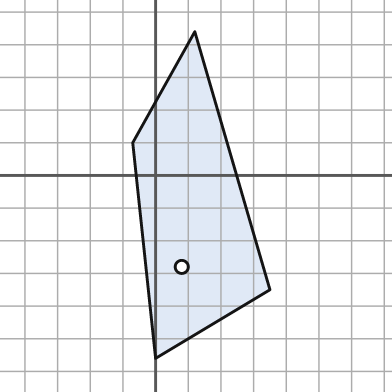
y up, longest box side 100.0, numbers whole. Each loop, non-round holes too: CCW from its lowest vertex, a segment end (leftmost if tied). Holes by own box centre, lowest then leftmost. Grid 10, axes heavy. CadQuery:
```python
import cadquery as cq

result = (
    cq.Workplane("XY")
    .moveTo(0.0, -56.0)
    .lineTo(35.0, -35.0)
    .lineTo(12.0, 44.0)
    .lineTo(-7.0, 10.0)
    .close()
    .moveTo(8.0, -28.0)
    .circle(2.0)
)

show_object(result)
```